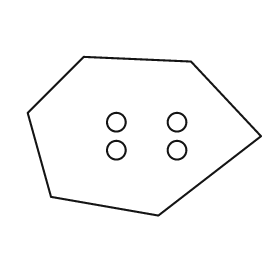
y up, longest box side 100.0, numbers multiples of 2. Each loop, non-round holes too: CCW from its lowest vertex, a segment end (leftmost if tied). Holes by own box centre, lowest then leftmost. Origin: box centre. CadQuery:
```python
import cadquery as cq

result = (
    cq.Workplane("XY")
    .moveTo(6.0, -34.0)
    .lineTo(50.0, 0.0)
    .lineTo(20.0, 32.0)
    .lineTo(-26.0, 34.0)
    .lineTo(-50.0, 10.0)
    .lineTo(-40.0, -26.0)
    .close()
    .moveTo(-12.0, -6.0)
    .circle(4.0)
    .moveTo(14.0, -6.0)
    .circle(4.0)
    .moveTo(-12.0, 6.0)
    .circle(4.0)
    .moveTo(14.0, 6.0)
    .circle(4.0)
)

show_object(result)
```